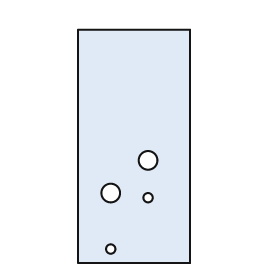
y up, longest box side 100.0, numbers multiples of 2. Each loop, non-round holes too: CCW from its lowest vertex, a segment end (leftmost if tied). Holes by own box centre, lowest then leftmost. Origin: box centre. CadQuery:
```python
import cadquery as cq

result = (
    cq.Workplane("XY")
    .moveTo(-24.0, -50.0)
    .lineTo(24.0, -50.0)
    .lineTo(24.0, 50.0)
    .lineTo(-24.0, 50.0)
    .close()
    .moveTo(-10.0, -44.0)
    .circle(2.0)
    .moveTo(6.0, -22.0)
    .circle(2.0)
    .moveTo(-10.0, -20.0)
    .circle(4.0)
    .moveTo(6.0, -6.0)
    .circle(4.0)
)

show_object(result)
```